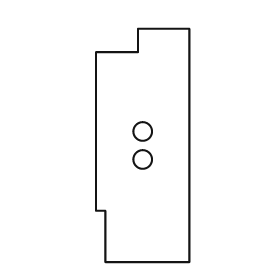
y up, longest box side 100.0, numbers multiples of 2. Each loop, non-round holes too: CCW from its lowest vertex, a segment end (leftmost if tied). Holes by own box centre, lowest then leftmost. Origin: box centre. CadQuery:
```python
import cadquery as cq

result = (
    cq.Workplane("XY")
    .moveTo(-16.0, -50.0)
    .lineTo(20.0, -50.0)
    .lineTo(20.0, 50.0)
    .lineTo(-2.0, 50.0)
    .lineTo(-2.0, 40.0)
    .lineTo(-20.0, 40.0)
    .lineTo(-20.0, -28.0)
    .lineTo(-16.0, -28.0)
    .close()
    .moveTo(0.0, -6.0)
    .circle(4.0)
    .moveTo(0.0, 6.0)
    .circle(4.0)
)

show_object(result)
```